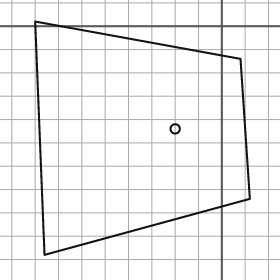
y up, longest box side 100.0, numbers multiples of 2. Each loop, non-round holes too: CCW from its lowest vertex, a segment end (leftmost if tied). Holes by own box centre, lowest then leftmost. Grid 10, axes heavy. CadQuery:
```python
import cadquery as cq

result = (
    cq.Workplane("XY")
    .moveTo(-76.0, -98.0)
    .lineTo(12.0, -74.0)
    .lineTo(8.0, -14.0)
    .lineTo(-80.0, 2.0)
    .close()
    .moveTo(-20.0, -44.0)
    .circle(2.0)
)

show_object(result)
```